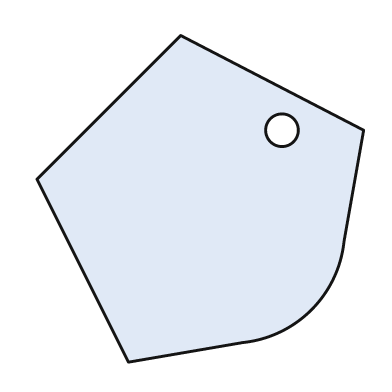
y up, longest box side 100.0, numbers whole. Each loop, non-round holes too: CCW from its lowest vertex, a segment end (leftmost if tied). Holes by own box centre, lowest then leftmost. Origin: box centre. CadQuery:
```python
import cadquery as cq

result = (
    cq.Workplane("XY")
    .moveTo(-22.0, -50.0)
    .lineTo(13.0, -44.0)
    .threePointArc((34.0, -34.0), (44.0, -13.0))
    .lineTo(50.0, 21.0)
    .lineTo(-6.0, 50.0)
    .lineTo(-50.0, 6.0)
    .close()
    .moveTo(25.0, 21.0)
    .circle(5.0)
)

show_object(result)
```